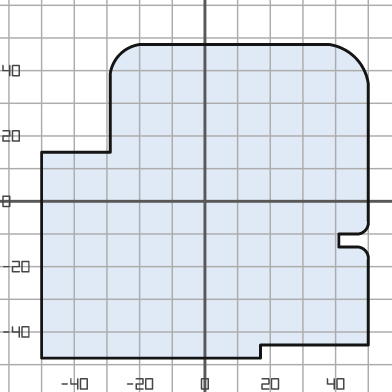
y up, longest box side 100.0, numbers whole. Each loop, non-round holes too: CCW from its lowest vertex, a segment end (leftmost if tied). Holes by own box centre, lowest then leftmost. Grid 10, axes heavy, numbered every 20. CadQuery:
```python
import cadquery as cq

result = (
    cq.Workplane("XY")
    .moveTo(-50.0, -48.0)
    .lineTo(17.0, -48.0)
    .lineTo(17.0, -44.0)
    .lineTo(50.0, -44.0)
    .lineTo(50.0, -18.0)
    .threePointArc((49.0, -15.0), (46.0, -14.0))
    .lineTo(41.0, -14.0)
    .lineTo(41.0, -10.0)
    .lineTo(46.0, -10.0)
    .threePointArc((49.0, -9.0), (50.0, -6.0))
    .lineTo(50.0, 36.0)
    .threePointArc((46.0, 44.0), (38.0, 48.0))
    .lineTo(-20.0, 48.0)
    .threePointArc((-26.0, 45.0), (-29.0, 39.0))
    .lineTo(-29.0, 15.0)
    .lineTo(-50.0, 15.0)
    .close()
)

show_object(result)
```